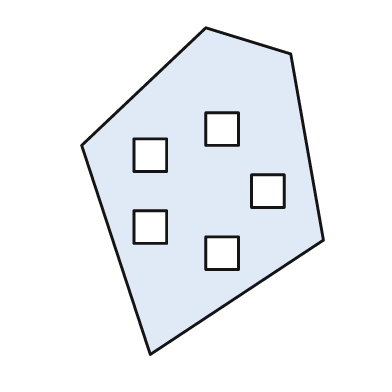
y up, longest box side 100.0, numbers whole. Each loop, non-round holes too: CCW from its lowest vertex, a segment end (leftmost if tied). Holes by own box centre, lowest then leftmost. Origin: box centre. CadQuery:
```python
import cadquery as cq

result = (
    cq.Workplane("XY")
    .moveTo(-16.0, -50.0)
    .lineTo(37.0, -15.0)
    .lineTo(27.0, 42.0)
    .lineTo(1.0, 50.0)
    .lineTo(-37.0, 14.0)
    .close()
    .moveTo(1.0, -24.0)
    .lineTo(11.0, -24.0)
    .lineTo(11.0, -14.0)
    .lineTo(1.0, -14.0)
    .close()
    .moveTo(-21.0, -16.0)
    .lineTo(-11.0, -16.0)
    .lineTo(-11.0, -6.0)
    .lineTo(-21.0, -6.0)
    .close()
    .moveTo(15.0, -5.0)
    .lineTo(25.0, -5.0)
    .lineTo(25.0, 5.0)
    .lineTo(15.0, 5.0)
    .close()
    .moveTo(-21.0, 6.0)
    .lineTo(-11.0, 6.0)
    .lineTo(-11.0, 16.0)
    .lineTo(-21.0, 16.0)
    .close()
    .moveTo(1.0, 14.0)
    .lineTo(11.0, 14.0)
    .lineTo(11.0, 24.0)
    .lineTo(1.0, 24.0)
    .close()
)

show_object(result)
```